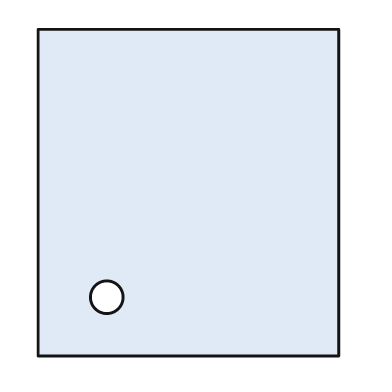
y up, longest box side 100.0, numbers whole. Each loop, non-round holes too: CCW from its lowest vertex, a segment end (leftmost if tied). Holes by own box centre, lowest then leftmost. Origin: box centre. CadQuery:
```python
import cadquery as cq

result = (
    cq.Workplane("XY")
    .moveTo(-46.0, -50.0)
    .lineTo(46.0, -50.0)
    .lineTo(46.0, 50.0)
    .lineTo(-46.0, 50.0)
    .close()
    .moveTo(-25.0, -32.0)
    .circle(5.0)
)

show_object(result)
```